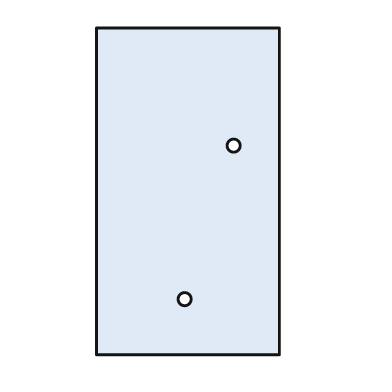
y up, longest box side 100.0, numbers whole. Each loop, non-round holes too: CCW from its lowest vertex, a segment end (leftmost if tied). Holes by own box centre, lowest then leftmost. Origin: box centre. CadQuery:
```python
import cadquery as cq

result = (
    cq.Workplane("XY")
    .moveTo(-28.0, -50.0)
    .lineTo(28.0, -50.0)
    .lineTo(28.0, 50.0)
    .lineTo(-28.0, 50.0)
    .close()
    .moveTo(-1.0, -33.0)
    .circle(2.0)
    .moveTo(14.0, 14.0)
    .circle(2.0)
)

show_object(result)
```